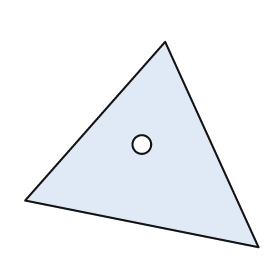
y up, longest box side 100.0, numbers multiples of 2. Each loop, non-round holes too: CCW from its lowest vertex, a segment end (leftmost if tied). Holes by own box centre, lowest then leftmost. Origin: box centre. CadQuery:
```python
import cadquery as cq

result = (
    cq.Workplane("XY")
    .moveTo(50.0, -44.0)
    .lineTo(10.0, 44.0)
    .lineTo(-50.0, -24.0)
    .close()
    .moveTo(0.0, 0.0)
    .circle(4.0)
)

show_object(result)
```